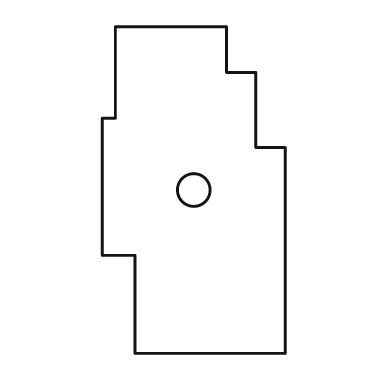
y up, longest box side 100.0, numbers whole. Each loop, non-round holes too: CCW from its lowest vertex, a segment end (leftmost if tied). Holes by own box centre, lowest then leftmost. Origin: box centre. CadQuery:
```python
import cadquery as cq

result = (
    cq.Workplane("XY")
    .moveTo(-18.0, -50.0)
    .lineTo(28.0, -50.0)
    .lineTo(28.0, 13.0)
    .lineTo(19.0, 13.0)
    .lineTo(19.0, 36.0)
    .lineTo(10.0, 36.0)
    .lineTo(10.0, 50.0)
    .lineTo(-24.0, 50.0)
    .lineTo(-24.0, 22.0)
    .lineTo(-28.0, 22.0)
    .lineTo(-28.0, -20.0)
    .lineTo(-18.0, -20.0)
    .close()
    .moveTo(0.0, 0.0)
    .circle(5.0)
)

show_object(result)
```